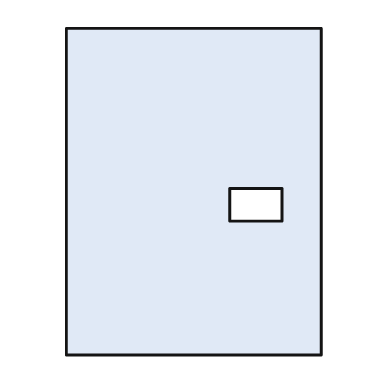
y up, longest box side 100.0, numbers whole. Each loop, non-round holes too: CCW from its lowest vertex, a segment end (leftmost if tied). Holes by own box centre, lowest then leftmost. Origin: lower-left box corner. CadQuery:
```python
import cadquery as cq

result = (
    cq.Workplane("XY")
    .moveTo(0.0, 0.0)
    .lineTo(78.0, 0.0)
    .lineTo(78.0, 100.0)
    .lineTo(0.0, 100.0)
    .close()
    .moveTo(50.0, 41.0)
    .lineTo(66.0, 41.0)
    .lineTo(66.0, 51.0)
    .lineTo(50.0, 51.0)
    .close()
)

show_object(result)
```